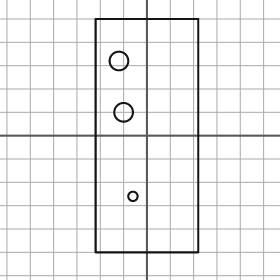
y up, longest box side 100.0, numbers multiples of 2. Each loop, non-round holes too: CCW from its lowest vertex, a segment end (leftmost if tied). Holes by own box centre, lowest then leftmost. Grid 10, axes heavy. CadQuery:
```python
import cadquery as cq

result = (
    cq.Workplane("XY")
    .moveTo(-22.0, -50.0)
    .lineTo(22.0, -50.0)
    .lineTo(22.0, 50.0)
    .lineTo(-22.0, 50.0)
    .close()
    .moveTo(-6.0, -26.0)
    .circle(2.0)
    .moveTo(-10.0, 10.0)
    .circle(4.0)
    .moveTo(-12.0, 32.0)
    .circle(4.0)
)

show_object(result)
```